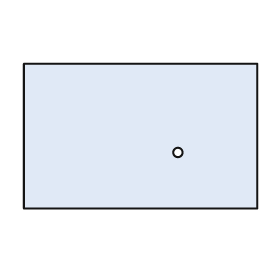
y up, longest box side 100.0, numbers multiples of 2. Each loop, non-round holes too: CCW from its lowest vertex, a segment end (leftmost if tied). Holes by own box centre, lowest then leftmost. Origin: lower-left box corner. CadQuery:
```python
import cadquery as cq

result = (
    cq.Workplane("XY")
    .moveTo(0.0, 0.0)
    .lineTo(100.0, 0.0)
    .lineTo(100.0, 62.0)
    .lineTo(0.0, 62.0)
    .close()
    .moveTo(66.0, 24.0)
    .circle(2.0)
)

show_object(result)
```